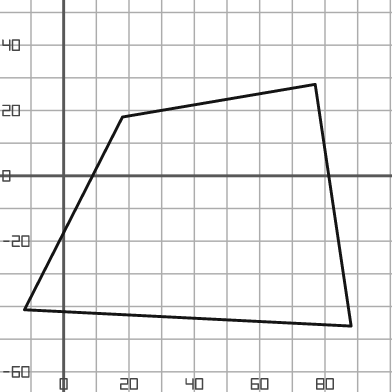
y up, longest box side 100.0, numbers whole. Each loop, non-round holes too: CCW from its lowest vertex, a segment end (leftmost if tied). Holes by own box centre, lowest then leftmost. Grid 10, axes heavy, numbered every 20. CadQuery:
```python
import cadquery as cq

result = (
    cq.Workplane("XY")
    .moveTo(88.0, -46.0)
    .lineTo(77.0, 28.0)
    .lineTo(18.0, 18.0)
    .lineTo(-12.0, -41.0)
    .close()
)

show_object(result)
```